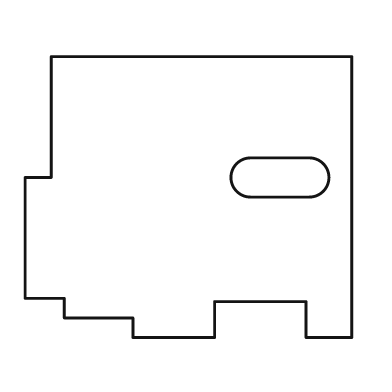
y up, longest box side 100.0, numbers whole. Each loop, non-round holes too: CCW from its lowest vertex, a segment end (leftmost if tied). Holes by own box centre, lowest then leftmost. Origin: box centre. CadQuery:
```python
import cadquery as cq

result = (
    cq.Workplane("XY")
    .moveTo(-17.0, -43.0)
    .lineTo(8.0, -43.0)
    .lineTo(8.0, -32.0)
    .lineTo(36.0, -32.0)
    .lineTo(36.0, -43.0)
    .lineTo(50.0, -43.0)
    .lineTo(50.0, 43.0)
    .lineTo(-42.0, 43.0)
    .lineTo(-42.0, 6.0)
    .lineTo(-50.0, 6.0)
    .lineTo(-50.0, -31.0)
    .lineTo(-38.0, -31.0)
    .lineTo(-38.0, -37.0)
    .lineTo(-17.0, -37.0)
    .close()
    .moveTo(19.0, 0.0)
    .lineTo(37.0, 0.0)
    .threePointArc((43.0, 6.0), (37.0, 12.0))
    .lineTo(19.0, 12.0)
    .threePointArc((13.0, 6.0), (19.0, 0.0))
    .close()
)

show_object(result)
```